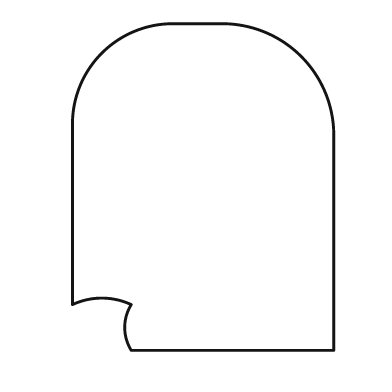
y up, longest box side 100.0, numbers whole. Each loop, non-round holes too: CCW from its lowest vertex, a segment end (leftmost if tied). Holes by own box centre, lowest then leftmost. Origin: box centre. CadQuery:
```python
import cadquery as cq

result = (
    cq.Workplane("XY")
    .moveTo(-22.0, -50.0)
    .lineTo(40.0, -50.0)
    .lineTo(40.0, 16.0)
    .threePointArc((30.0, 40.0), (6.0, 50.0))
    .lineTo(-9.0, 50.0)
    .threePointArc((-31.0, 41.0), (-40.0, 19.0))
    .lineTo(-40.0, -36.0)
    .threePointArc((-31.0, -34.0), (-22.0, -36.0))
    .threePointArc((-24.0, -43.0), (-22.0, -50.0))
    .close()
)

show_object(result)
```